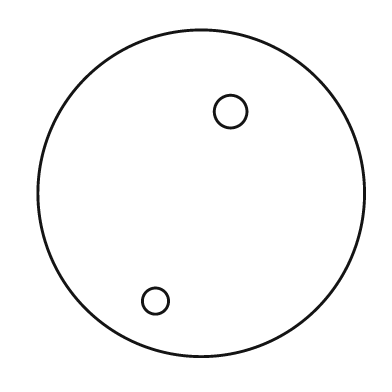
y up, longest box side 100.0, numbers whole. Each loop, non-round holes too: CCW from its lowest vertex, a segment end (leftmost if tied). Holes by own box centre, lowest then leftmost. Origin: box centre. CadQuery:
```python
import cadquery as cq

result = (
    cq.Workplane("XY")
    .moveTo(0.0, 0.0)
    .circle(50.0)
    .moveTo(-14.0, -33.0)
    .circle(4.0)
    .moveTo(9.0, 25.0)
    .circle(5.0)
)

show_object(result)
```